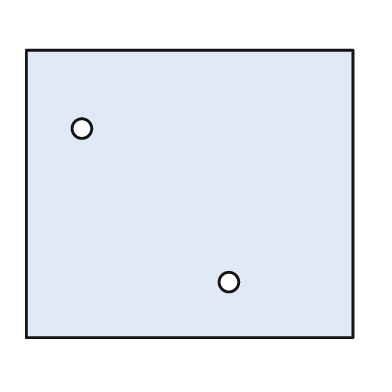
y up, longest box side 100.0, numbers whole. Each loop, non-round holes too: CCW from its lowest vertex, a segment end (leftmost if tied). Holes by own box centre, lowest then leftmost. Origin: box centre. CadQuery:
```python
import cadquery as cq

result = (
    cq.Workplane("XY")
    .moveTo(-50.0, -44.0)
    .lineTo(50.0, -44.0)
    .lineTo(50.0, 44.0)
    .lineTo(-50.0, 44.0)
    .close()
    .moveTo(12.0, -27.0)
    .circle(3.0)
    .moveTo(-33.0, 20.0)
    .circle(3.0)
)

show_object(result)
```